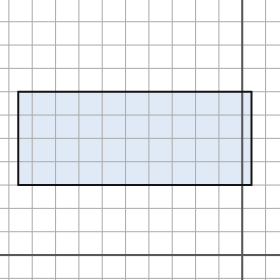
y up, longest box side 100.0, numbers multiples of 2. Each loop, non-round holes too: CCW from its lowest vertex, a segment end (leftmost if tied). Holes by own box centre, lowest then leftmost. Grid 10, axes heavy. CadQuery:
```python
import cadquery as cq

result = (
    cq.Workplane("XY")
    .moveTo(-96.0, 30.0)
    .lineTo(4.0, 30.0)
    .lineTo(4.0, 70.0)
    .lineTo(-96.0, 70.0)
    .close()
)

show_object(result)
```